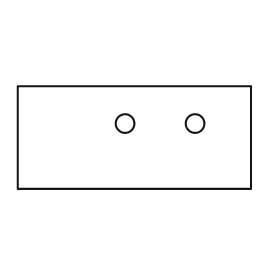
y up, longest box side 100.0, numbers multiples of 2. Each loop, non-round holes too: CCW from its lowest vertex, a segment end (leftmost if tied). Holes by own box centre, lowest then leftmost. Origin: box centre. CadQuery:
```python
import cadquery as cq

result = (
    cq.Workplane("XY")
    .moveTo(-50.0, -22.0)
    .lineTo(50.0, -22.0)
    .lineTo(50.0, 22.0)
    .lineTo(-50.0, 22.0)
    .close()
    .moveTo(-4.0, 6.0)
    .circle(4.0)
    .moveTo(26.0, 6.0)
    .circle(4.0)
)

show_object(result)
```